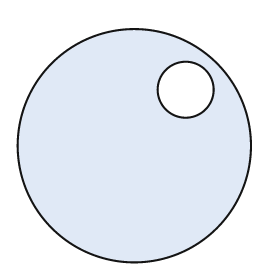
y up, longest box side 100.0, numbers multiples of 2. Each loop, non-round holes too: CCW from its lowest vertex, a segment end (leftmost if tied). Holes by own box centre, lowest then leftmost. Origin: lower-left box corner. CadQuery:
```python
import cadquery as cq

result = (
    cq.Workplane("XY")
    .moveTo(50.0, 50.0)
    .circle(50.0)
    .moveTo(72.0, 74.0)
    .circle(12.0)
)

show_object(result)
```